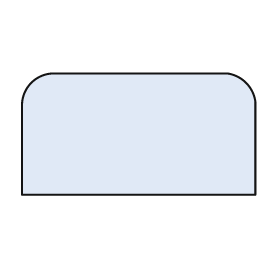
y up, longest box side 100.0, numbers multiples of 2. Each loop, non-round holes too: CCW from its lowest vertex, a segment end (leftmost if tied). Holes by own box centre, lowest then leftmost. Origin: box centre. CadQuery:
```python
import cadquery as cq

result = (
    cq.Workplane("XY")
    .moveTo(-50.0, -26.0)
    .lineTo(50.0, -26.0)
    .lineTo(50.0, 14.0)
    .threePointArc((46.0, 22.0), (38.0, 26.0))
    .lineTo(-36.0, 26.0)
    .threePointArc((-46.0, 22.0), (-50.0, 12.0))
    .close()
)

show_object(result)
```